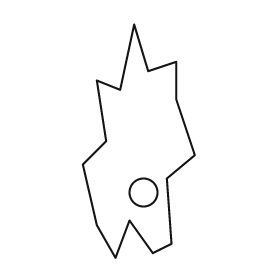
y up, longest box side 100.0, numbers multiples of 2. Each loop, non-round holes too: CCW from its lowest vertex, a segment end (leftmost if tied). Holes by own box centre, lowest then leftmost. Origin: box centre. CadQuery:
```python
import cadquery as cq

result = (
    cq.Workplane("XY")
    .moveTo(-10.0, -50.0)
    .lineTo(-4.0, -34.0)
    .lineTo(6.0, -48.0)
    .lineTo(14.0, -44.0)
    .lineTo(12.0, -16.0)
    .lineTo(24.0, -6.0)
    .lineTo(16.0, 18.0)
    .lineTo(16.0, 34.0)
    .lineTo(4.0, 30.0)
    .lineTo(-2.0, 50.0)
    .lineTo(-8.0, 22.0)
    .lineTo(-18.0, 26.0)
    .lineTo(-14.0, 0.0)
    .lineTo(-24.0, -10.0)
    .lineTo(-18.0, -36.0)
    .close()
    .moveTo(2.0, -22.0)
    .circle(6.0)
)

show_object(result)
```